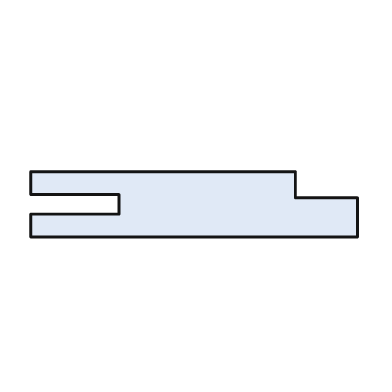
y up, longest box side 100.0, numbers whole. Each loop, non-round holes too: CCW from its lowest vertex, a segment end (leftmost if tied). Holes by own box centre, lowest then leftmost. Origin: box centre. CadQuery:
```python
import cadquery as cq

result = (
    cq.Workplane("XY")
    .moveTo(-50.0, -10.0)
    .lineTo(50.0, -10.0)
    .lineTo(50.0, 2.0)
    .lineTo(31.0, 2.0)
    .lineTo(31.0, 10.0)
    .lineTo(-50.0, 10.0)
    .lineTo(-50.0, 3.0)
    .lineTo(-23.0, 3.0)
    .lineTo(-23.0, -3.0)
    .lineTo(-50.0, -3.0)
    .close()
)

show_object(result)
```